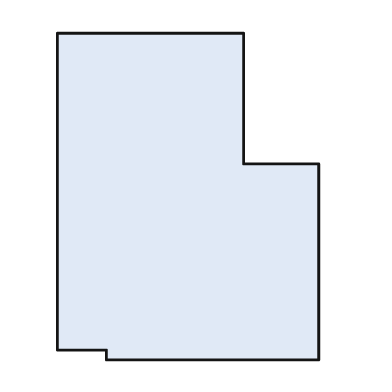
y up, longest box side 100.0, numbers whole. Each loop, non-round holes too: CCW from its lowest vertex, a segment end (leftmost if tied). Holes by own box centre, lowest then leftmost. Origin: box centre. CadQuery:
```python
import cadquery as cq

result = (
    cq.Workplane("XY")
    .moveTo(-25.0, -50.0)
    .lineTo(40.0, -50.0)
    .lineTo(40.0, 10.0)
    .lineTo(17.0, 10.0)
    .lineTo(17.0, 50.0)
    .lineTo(-40.0, 50.0)
    .lineTo(-40.0, -47.0)
    .lineTo(-25.0, -47.0)
    .close()
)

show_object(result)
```